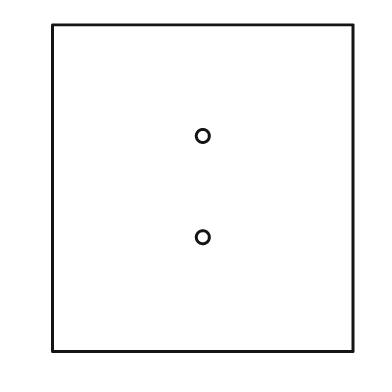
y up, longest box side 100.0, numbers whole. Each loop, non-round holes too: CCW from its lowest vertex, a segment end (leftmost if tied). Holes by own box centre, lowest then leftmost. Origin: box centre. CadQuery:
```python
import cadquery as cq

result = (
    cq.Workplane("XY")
    .moveTo(-46.0, -50.0)
    .lineTo(46.0, -50.0)
    .lineTo(46.0, 50.0)
    .lineTo(-46.0, 50.0)
    .close()
    .moveTo(0.0, -15.0)
    .circle(2.0)
    .moveTo(0.0, 16.0)
    .circle(2.0)
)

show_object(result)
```